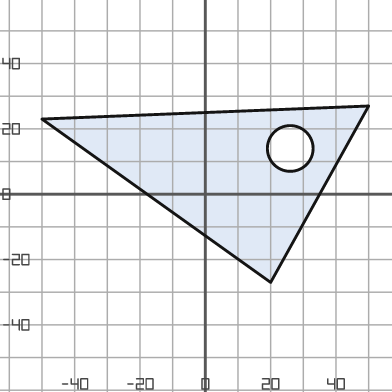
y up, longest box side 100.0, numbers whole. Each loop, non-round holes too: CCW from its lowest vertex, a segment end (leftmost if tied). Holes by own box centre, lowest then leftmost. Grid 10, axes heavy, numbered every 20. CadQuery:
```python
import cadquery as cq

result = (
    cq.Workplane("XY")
    .moveTo(20.0, -27.0)
    .lineTo(50.0, 27.0)
    .lineTo(-50.0, 23.0)
    .close()
    .moveTo(26.0, 14.0)
    .circle(7.0)
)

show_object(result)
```